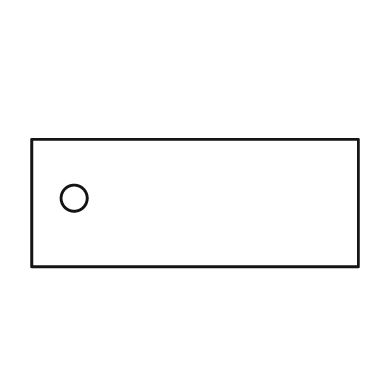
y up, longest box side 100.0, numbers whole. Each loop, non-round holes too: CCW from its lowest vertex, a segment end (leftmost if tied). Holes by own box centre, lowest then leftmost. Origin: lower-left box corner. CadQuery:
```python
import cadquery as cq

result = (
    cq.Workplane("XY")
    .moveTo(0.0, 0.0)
    .lineTo(100.0, 0.0)
    .lineTo(100.0, 39.0)
    .lineTo(0.0, 39.0)
    .close()
    .moveTo(13.0, 21.0)
    .circle(4.0)
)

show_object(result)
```